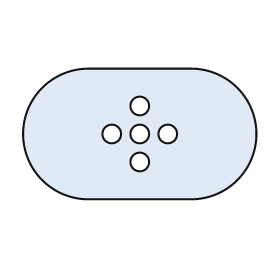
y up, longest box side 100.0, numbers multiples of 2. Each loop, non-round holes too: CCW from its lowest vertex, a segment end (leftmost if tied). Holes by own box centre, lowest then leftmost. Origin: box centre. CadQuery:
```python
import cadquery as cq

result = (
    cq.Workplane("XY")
    .moveTo(-22.0, -28.0)
    .lineTo(22.0, -28.0)
    .threePointArc((50.0, 0.0), (22.0, 28.0))
    .lineTo(-22.0, 28.0)
    .threePointArc((-50.0, 0.0), (-22.0, -28.0))
    .close()
    .moveTo(0.0, -12.0)
    .circle(4.0)
    .moveTo(-12.0, 0.0)
    .circle(4.0)
    .moveTo(0.0, 0.0)
    .circle(4.0)
    .moveTo(12.0, 0.0)
    .circle(4.0)
    .moveTo(0.0, 12.0)
    .circle(4.0)
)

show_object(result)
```